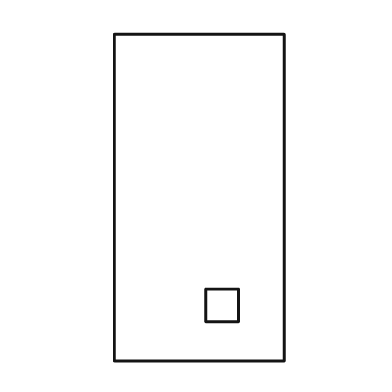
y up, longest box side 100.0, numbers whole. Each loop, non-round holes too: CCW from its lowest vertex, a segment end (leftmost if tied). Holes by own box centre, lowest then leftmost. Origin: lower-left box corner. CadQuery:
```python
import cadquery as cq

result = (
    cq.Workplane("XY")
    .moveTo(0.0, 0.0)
    .lineTo(52.0, 0.0)
    .lineTo(52.0, 100.0)
    .lineTo(0.0, 100.0)
    .close()
    .moveTo(28.0, 12.0)
    .lineTo(38.0, 12.0)
    .lineTo(38.0, 22.0)
    .lineTo(28.0, 22.0)
    .close()
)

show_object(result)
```